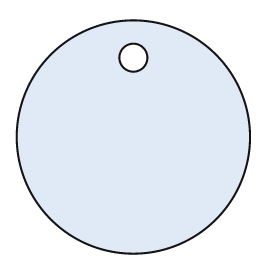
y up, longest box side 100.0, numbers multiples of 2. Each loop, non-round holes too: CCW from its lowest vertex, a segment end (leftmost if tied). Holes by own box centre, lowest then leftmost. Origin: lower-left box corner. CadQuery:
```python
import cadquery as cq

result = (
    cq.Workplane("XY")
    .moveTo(50.0, 50.0)
    .circle(50.0)
    .moveTo(50.0, 84.0)
    .circle(6.0)
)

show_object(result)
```